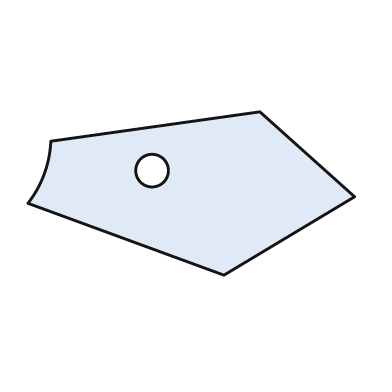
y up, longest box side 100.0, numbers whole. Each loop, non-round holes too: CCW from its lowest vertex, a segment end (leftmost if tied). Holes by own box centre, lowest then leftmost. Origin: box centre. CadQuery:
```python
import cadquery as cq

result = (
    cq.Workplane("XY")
    .moveTo(10.0, -25.0)
    .lineTo(50.0, -1.0)
    .lineTo(21.0, 25.0)
    .lineTo(-43.0, 16.0)
    .threePointArc((-45.0, 6.0), (-50.0, -3.0))
    .close()
    .moveTo(-12.0, 7.0)
    .circle(5.0)
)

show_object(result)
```